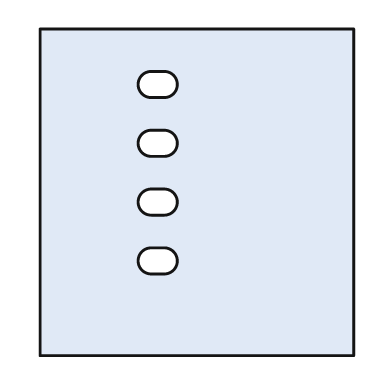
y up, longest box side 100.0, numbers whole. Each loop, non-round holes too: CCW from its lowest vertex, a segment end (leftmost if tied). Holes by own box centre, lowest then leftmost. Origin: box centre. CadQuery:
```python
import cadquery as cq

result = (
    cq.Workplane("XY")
    .moveTo(-48.0, -50.0)
    .lineTo(48.0, -50.0)
    .lineTo(48.0, 50.0)
    .lineTo(-48.0, 50.0)
    .close()
    .moveTo(-14.0, -25.0)
    .lineTo(-10.0, -25.0)
    .threePointArc((-6.0, -21.0), (-10.0, -17.0))
    .lineTo(-14.0, -17.0)
    .threePointArc((-18.0, -21.0), (-14.0, -25.0))
    .close()
    .moveTo(-14.0, -7.0)
    .lineTo(-10.0, -7.0)
    .threePointArc((-6.0, -3.0), (-10.0, 1.0))
    .lineTo(-14.0, 1.0)
    .threePointArc((-18.0, -3.0), (-14.0, -7.0))
    .close()
    .moveTo(-14.0, 11.0)
    .lineTo(-10.0, 11.0)
    .threePointArc((-6.0, 15.0), (-10.0, 19.0))
    .lineTo(-14.0, 19.0)
    .threePointArc((-18.0, 15.0), (-14.0, 11.0))
    .close()
    .moveTo(-14.0, 29.0)
    .lineTo(-10.0, 29.0)
    .threePointArc((-6.0, 33.0), (-10.0, 37.0))
    .lineTo(-14.0, 37.0)
    .threePointArc((-18.0, 33.0), (-14.0, 29.0))
    .close()
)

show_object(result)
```